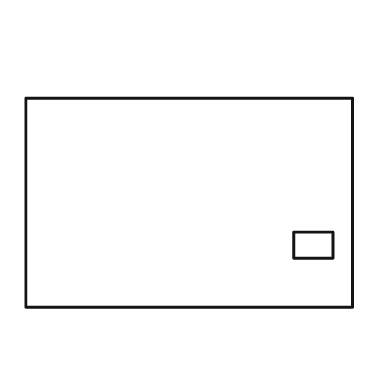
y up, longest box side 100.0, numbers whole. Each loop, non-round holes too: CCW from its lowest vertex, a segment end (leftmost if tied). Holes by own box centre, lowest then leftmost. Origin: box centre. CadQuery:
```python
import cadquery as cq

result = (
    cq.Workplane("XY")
    .moveTo(-50.0, -32.0)
    .lineTo(50.0, -32.0)
    .lineTo(50.0, 32.0)
    .lineTo(-50.0, 32.0)
    .close()
    .moveTo(32.0, -17.0)
    .lineTo(44.0, -17.0)
    .lineTo(44.0, -9.0)
    .lineTo(32.0, -9.0)
    .close()
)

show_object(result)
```